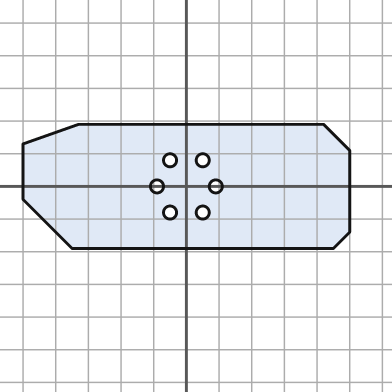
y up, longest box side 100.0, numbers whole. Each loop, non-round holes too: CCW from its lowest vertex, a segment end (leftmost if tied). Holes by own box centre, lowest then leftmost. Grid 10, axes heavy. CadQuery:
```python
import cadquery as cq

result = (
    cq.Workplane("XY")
    .moveTo(-35.0, -19.0)
    .lineTo(45.0, -19.0)
    .lineTo(50.0, -14.0)
    .lineTo(50.0, 11.0)
    .lineTo(42.0, 19.0)
    .lineTo(-33.0, 19.0)
    .lineTo(-50.0, 13.0)
    .lineTo(-50.0, -4.0)
    .close()
    .moveTo(-5.0, -8.0)
    .circle(2.0)
    .moveTo(5.0, -8.0)
    .circle(2.0)
    .moveTo(-9.0, 0.0)
    .circle(2.0)
    .moveTo(9.0, 0.0)
    .circle(2.0)
    .moveTo(-5.0, 8.0)
    .circle(2.0)
    .moveTo(5.0, 8.0)
    .circle(2.0)
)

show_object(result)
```